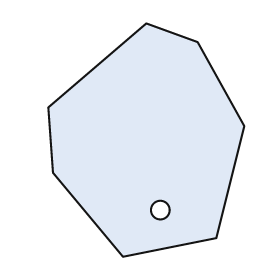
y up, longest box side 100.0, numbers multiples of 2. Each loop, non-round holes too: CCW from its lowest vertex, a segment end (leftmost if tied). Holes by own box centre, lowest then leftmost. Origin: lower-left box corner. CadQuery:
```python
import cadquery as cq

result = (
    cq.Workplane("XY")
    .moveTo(32.0, 0.0)
    .lineTo(72.0, 8.0)
    .lineTo(84.0, 56.0)
    .lineTo(64.0, 92.0)
    .lineTo(42.0, 100.0)
    .lineTo(0.0, 64.0)
    .lineTo(2.0, 36.0)
    .close()
    .moveTo(48.0, 20.0)
    .circle(4.0)
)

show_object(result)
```